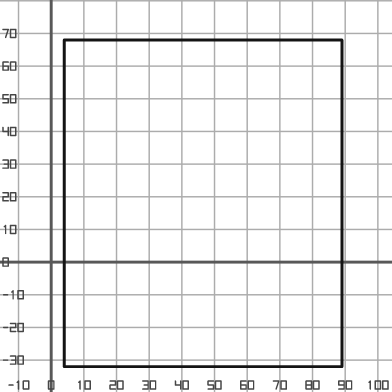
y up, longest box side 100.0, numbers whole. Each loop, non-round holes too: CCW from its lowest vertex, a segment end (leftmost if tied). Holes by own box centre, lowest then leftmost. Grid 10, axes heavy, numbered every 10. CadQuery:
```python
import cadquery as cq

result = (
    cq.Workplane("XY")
    .moveTo(4.0, -32.0)
    .lineTo(89.0, -32.0)
    .lineTo(89.0, 68.0)
    .lineTo(4.0, 68.0)
    .close()
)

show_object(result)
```